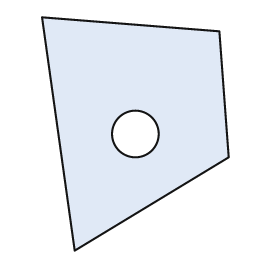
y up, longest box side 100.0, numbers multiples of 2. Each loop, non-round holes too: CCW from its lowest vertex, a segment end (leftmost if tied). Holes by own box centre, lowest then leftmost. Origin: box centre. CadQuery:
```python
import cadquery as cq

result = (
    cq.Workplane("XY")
    .moveTo(-26.0, -50.0)
    .lineTo(40.0, -10.0)
    .lineTo(36.0, 44.0)
    .lineTo(-40.0, 50.0)
    .close()
    .moveTo(0.0, 0.0)
    .circle(10.0)
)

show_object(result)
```